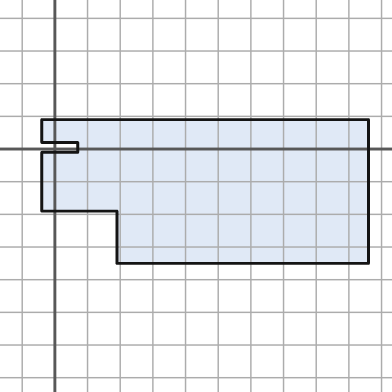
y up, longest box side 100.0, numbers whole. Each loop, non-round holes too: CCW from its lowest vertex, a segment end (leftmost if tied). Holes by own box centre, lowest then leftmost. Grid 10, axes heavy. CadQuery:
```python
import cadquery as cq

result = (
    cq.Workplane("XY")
    .moveTo(19.0, -35.0)
    .lineTo(96.0, -35.0)
    .lineTo(96.0, 9.0)
    .lineTo(-4.0, 9.0)
    .lineTo(-4.0, 2.0)
    .lineTo(7.0, 2.0)
    .lineTo(7.0, -1.0)
    .lineTo(-4.0, -1.0)
    .lineTo(-4.0, -19.0)
    .lineTo(19.0, -19.0)
    .close()
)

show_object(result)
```